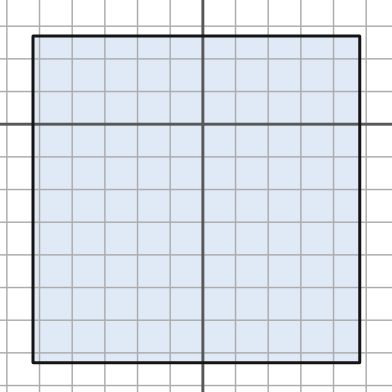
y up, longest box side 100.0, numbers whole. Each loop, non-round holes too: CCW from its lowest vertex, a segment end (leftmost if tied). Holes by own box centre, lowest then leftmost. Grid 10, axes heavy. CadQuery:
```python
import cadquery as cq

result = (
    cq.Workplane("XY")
    .moveTo(-52.0, -73.0)
    .lineTo(48.0, -73.0)
    .lineTo(48.0, 27.0)
    .lineTo(-52.0, 27.0)
    .close()
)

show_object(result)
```